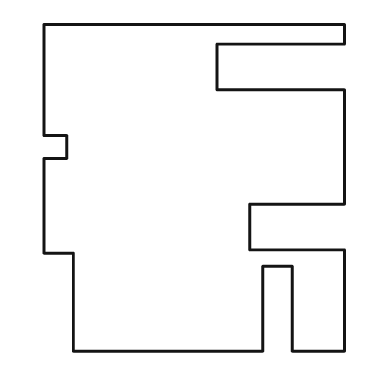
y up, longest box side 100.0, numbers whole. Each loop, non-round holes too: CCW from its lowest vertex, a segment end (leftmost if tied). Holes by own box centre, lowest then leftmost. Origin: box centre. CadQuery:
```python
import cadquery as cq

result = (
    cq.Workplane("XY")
    .moveTo(-37.0, -50.0)
    .lineTo(21.0, -50.0)
    .lineTo(21.0, -24.0)
    .lineTo(30.0, -24.0)
    .lineTo(30.0, -50.0)
    .lineTo(46.0, -50.0)
    .lineTo(46.0, -19.0)
    .lineTo(17.0, -19.0)
    .lineTo(17.0, -5.0)
    .lineTo(46.0, -5.0)
    .lineTo(46.0, 30.0)
    .lineTo(7.0, 30.0)
    .lineTo(7.0, 44.0)
    .lineTo(46.0, 44.0)
    .lineTo(46.0, 50.0)
    .lineTo(-46.0, 50.0)
    .lineTo(-46.0, 16.0)
    .lineTo(-39.0, 16.0)
    .lineTo(-39.0, 9.0)
    .lineTo(-46.0, 9.0)
    .lineTo(-46.0, -20.0)
    .lineTo(-37.0, -20.0)
    .close()
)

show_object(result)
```